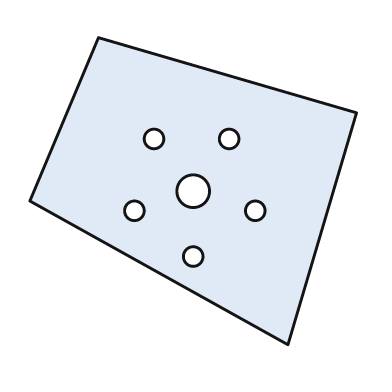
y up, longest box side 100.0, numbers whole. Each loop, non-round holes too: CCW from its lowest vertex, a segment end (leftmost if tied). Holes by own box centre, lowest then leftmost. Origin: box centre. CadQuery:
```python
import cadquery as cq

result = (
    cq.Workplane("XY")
    .moveTo(29.0, -47.0)
    .lineTo(50.0, 24.0)
    .lineTo(-29.0, 47.0)
    .lineTo(-50.0, -3.0)
    .close()
    .moveTo(0.0, -20.0)
    .circle(3.0)
    .moveTo(-18.0, -6.0)
    .circle(3.0)
    .moveTo(19.0, -6.0)
    .circle(3.0)
    .moveTo(0.0, 0.0)
    .circle(5.0)
    .moveTo(-12.0, 16.0)
    .circle(3.0)
    .moveTo(11.0, 16.0)
    .circle(3.0)
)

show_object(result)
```